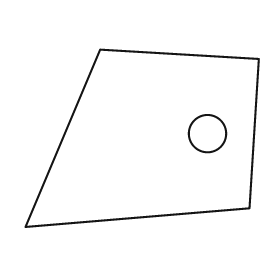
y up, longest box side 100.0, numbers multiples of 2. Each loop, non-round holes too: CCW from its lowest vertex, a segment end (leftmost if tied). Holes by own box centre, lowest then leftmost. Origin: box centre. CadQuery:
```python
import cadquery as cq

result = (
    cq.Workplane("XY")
    .moveTo(-50.0, -38.0)
    .lineTo(46.0, -30.0)
    .lineTo(50.0, 34.0)
    .lineTo(-18.0, 38.0)
    .close()
    .moveTo(28.0, 2.0)
    .circle(8.0)
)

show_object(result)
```